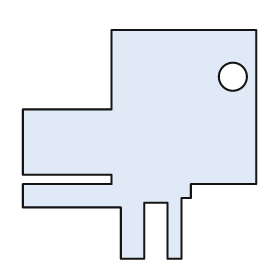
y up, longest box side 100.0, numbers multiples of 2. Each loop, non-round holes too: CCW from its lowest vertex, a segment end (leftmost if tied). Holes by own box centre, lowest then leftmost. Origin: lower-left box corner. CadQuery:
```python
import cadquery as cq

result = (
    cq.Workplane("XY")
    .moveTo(42.0, 0.0)
    .lineTo(52.0, 0.0)
    .lineTo(52.0, 24.0)
    .lineTo(62.0, 24.0)
    .lineTo(62.0, 0.0)
    .lineTo(68.0, 0.0)
    .lineTo(68.0, 26.0)
    .lineTo(72.0, 26.0)
    .lineTo(72.0, 32.0)
    .lineTo(100.0, 32.0)
    .lineTo(100.0, 98.0)
    .lineTo(38.0, 98.0)
    .lineTo(38.0, 64.0)
    .lineTo(0.0, 64.0)
    .lineTo(0.0, 36.0)
    .lineTo(38.0, 36.0)
    .lineTo(38.0, 32.0)
    .lineTo(0.0, 32.0)
    .lineTo(0.0, 22.0)
    .lineTo(42.0, 22.0)
    .close()
    .moveTo(90.0, 78.0)
    .circle(6.0)
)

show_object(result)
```